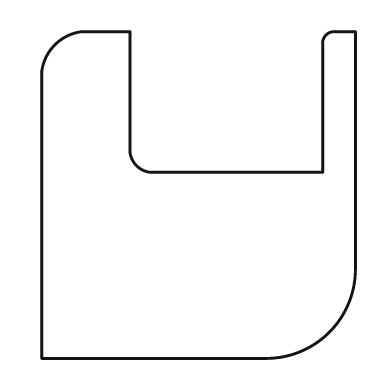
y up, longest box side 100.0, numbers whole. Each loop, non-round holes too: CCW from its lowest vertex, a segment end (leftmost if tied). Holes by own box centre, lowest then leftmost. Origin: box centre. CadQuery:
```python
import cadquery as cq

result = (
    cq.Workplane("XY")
    .moveTo(-48.0, -50.0)
    .lineTo(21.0, -50.0)
    .threePointArc((40.0, -42.0), (48.0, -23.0))
    .lineTo(48.0, 50.0)
    .lineTo(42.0, 50.0)
    .threePointArc((39.0, 49.0), (38.0, 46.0))
    .lineTo(38.0, 7.0)
    .lineTo(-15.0, 7.0)
    .threePointArc((-19.0, 9.0), (-21.0, 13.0))
    .lineTo(-21.0, 50.0)
    .lineTo(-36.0, 50.0)
    .threePointArc((-44.0, 46.0), (-48.0, 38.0))
    .close()
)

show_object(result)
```